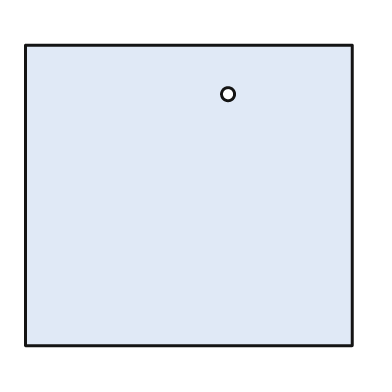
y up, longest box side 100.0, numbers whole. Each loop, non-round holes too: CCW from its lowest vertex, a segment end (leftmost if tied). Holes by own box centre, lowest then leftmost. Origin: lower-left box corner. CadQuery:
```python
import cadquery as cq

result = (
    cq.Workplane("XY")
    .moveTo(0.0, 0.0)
    .lineTo(100.0, 0.0)
    .lineTo(100.0, 92.0)
    .lineTo(0.0, 92.0)
    .close()
    .moveTo(62.0, 77.0)
    .circle(2.0)
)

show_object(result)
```